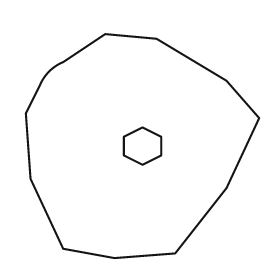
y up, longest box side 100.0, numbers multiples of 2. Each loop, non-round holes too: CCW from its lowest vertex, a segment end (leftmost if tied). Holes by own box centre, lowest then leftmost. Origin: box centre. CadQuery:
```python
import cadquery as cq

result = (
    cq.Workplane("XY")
    .moveTo(-12.0, -48.0)
    .lineTo(14.0, -46.0)
    .lineTo(36.0, -18.0)
    .lineTo(50.0, 12.0)
    .lineTo(36.0, 28.0)
    .lineTo(6.0, 46.0)
    .lineTo(-16.0, 48.0)
    .lineTo(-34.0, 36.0)
    .threePointArc((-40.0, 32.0), (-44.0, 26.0))
    .lineTo(-50.0, 14.0)
    .lineTo(-48.0, -14.0)
    .lineTo(-34.0, -44.0)
    .close()
    .moveTo(0.0, -8.0)
    .lineTo(8.0, -4.0)
    .lineTo(8.0, 4.0)
    .lineTo(0.0, 8.0)
    .lineTo(-8.0, 4.0)
    .lineTo(-8.0, -4.0)
    .close()
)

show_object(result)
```